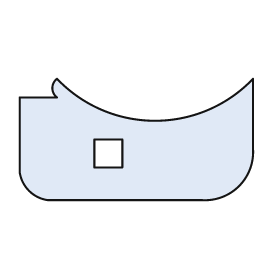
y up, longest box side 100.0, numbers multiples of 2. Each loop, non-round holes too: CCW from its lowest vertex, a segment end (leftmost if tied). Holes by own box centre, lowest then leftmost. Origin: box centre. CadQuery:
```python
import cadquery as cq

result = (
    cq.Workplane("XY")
    .moveTo(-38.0, -26.0)
    .lineTo(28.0, -26.0)
    .threePointArc((44.0, -20.0), (50.0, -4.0))
    .lineTo(50.0, 26.0)
    .threePointArc((8.0, 8.0), (-34.0, 26.0))
    .threePointArc((-36.0, 22.0), (-34.0, 18.0))
    .lineTo(-50.0, 18.0)
    .lineTo(-50.0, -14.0)
    .threePointArc((-46.0, -22.0), (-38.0, -26.0))
    .close()
    .moveTo(-18.0, -12.0)
    .lineTo(-6.0, -12.0)
    .lineTo(-6.0, 0.0)
    .lineTo(-18.0, 0.0)
    .close()
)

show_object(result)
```